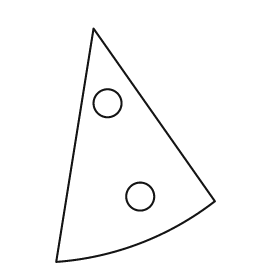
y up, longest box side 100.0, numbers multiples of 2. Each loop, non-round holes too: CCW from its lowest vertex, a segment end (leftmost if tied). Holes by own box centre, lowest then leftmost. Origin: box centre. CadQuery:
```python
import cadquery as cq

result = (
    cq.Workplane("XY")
    .moveTo(-34.0, -50.0)
    .threePointArc((2.0, -42.0), (34.0, -24.0))
    .lineTo(-18.0, 50.0)
    .close()
    .moveTo(2.0, -22.0)
    .circle(6.0)
    .moveTo(-12.0, 18.0)
    .circle(6.0)
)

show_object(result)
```